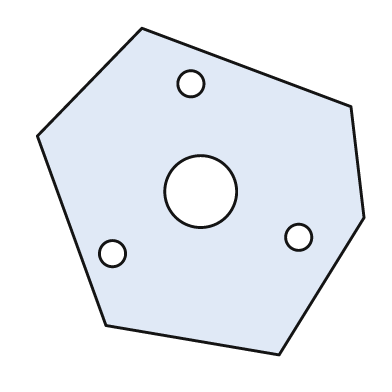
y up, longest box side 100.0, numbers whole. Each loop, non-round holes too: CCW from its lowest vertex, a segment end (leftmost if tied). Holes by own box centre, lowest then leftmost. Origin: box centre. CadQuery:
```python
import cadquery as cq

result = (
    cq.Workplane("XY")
    .moveTo(24.0, -50.0)
    .lineTo(50.0, -8.0)
    .lineTo(46.0, 26.0)
    .lineTo(-18.0, 50.0)
    .lineTo(-50.0, 17.0)
    .lineTo(-29.0, -41.0)
    .close()
    .moveTo(-27.0, -19.0)
    .circle(4.0)
    .moveTo(30.0, -14.0)
    .circle(4.0)
    .moveTo(0.0, 0.0)
    .circle(11.0)
    .moveTo(-3.0, 33.0)
    .circle(4.0)
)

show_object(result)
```